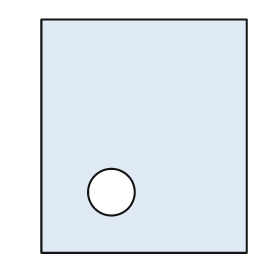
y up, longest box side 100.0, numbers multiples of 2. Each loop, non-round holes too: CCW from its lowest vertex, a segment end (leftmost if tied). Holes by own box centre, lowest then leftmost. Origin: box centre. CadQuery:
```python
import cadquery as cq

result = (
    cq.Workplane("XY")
    .moveTo(-44.0, -50.0)
    .lineTo(44.0, -50.0)
    .lineTo(44.0, 50.0)
    .lineTo(-44.0, 50.0)
    .close()
    .moveTo(-14.0, -24.0)
    .circle(10.0)
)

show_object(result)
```